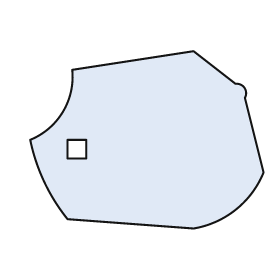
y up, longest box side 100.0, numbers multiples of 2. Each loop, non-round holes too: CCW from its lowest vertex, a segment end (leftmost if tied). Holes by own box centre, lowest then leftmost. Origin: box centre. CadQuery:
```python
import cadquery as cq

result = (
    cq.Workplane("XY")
    .moveTo(20.0, -38.0)
    .threePointArc((38.0, -30.0), (50.0, -14.0))
    .lineTo(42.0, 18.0)
    .threePointArc((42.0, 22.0), (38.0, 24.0))
    .lineTo(20.0, 38.0)
    .lineTo(-32.0, 30.0)
    .threePointArc((-36.0, 12.0), (-50.0, 0.0))
    .threePointArc((-44.0, -18.0), (-34.0, -34.0))
    .close()
    .moveTo(-34.0, -8.0)
    .lineTo(-26.0, -8.0)
    .lineTo(-26.0, 0.0)
    .lineTo(-34.0, 0.0)
    .close()
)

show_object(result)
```